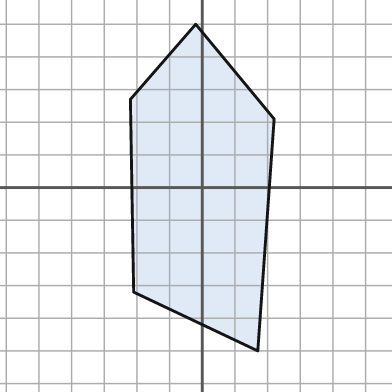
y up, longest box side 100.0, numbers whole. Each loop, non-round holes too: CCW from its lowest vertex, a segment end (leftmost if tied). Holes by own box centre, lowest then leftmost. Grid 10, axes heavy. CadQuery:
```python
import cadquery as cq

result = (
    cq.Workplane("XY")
    .moveTo(17.0, -50.0)
    .lineTo(22.0, 21.0)
    .lineTo(-2.0, 50.0)
    .lineTo(-22.0, 27.0)
    .lineTo(-21.0, -32.0)
    .close()
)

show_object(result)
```